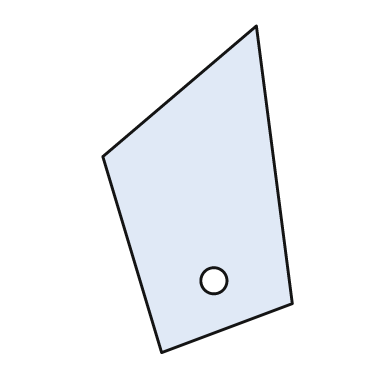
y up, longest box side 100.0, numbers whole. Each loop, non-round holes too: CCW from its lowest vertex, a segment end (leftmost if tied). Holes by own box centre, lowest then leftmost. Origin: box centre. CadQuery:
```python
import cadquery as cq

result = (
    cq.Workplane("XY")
    .moveTo(-11.0, -50.0)
    .lineTo(29.0, -35.0)
    .lineTo(18.0, 50.0)
    .lineTo(-29.0, 10.0)
    .close()
    .moveTo(5.0, -28.0)
    .circle(4.0)
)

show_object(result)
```